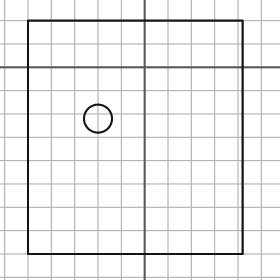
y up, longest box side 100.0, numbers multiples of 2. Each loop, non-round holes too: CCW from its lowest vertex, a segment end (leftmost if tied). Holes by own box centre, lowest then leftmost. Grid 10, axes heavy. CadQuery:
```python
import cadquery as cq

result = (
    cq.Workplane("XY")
    .moveTo(-50.0, -80.0)
    .lineTo(42.0, -80.0)
    .lineTo(42.0, 20.0)
    .lineTo(-50.0, 20.0)
    .close()
    .moveTo(-20.0, -22.0)
    .circle(6.0)
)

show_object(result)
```